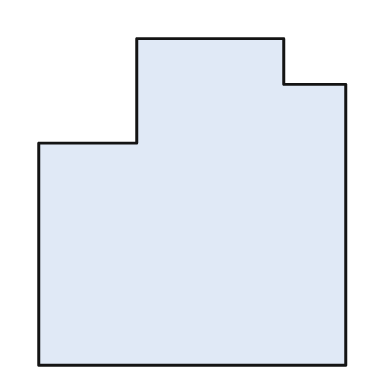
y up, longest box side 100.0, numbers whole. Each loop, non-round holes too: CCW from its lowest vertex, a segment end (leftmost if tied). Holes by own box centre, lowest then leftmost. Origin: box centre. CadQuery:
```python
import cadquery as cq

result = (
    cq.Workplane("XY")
    .moveTo(-47.0, -50.0)
    .lineTo(47.0, -50.0)
    .lineTo(47.0, 36.0)
    .lineTo(28.0, 36.0)
    .lineTo(28.0, 50.0)
    .lineTo(-17.0, 50.0)
    .lineTo(-17.0, 18.0)
    .lineTo(-47.0, 18.0)
    .close()
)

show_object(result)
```